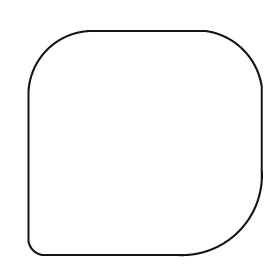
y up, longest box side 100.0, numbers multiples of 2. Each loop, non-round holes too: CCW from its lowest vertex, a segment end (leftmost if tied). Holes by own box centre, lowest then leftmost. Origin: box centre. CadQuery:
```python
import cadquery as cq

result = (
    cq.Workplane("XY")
    .moveTo(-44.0, -48.0)
    .lineTo(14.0, -48.0)
    .threePointArc((40.0, -38.0), (50.0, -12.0))
    .lineTo(50.0, 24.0)
    .threePointArc((42.0, 40.0), (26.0, 48.0))
    .lineTo(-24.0, 48.0)
    .threePointArc((-42.0, 40.0), (-50.0, 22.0))
    .lineTo(-50.0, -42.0)
    .threePointArc((-48.0, -46.0), (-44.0, -48.0))
    .close()
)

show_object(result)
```